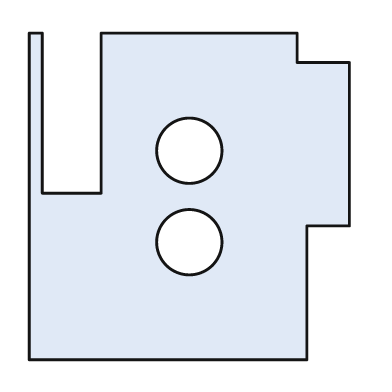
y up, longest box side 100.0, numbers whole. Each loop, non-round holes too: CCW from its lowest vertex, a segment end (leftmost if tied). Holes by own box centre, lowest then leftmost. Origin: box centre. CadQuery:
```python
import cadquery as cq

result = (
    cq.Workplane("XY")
    .moveTo(-49.0, -50.0)
    .lineTo(36.0, -50.0)
    .lineTo(36.0, -9.0)
    .lineTo(49.0, -9.0)
    .lineTo(49.0, 41.0)
    .lineTo(33.0, 41.0)
    .lineTo(33.0, 50.0)
    .lineTo(-27.0, 50.0)
    .lineTo(-27.0, 1.0)
    .lineTo(-45.0, 1.0)
    .lineTo(-45.0, 50.0)
    .lineTo(-49.0, 50.0)
    .close()
    .moveTo(0.0, -14.0)
    .circle(10.0)
    .moveTo(0.0, 14.0)
    .circle(10.0)
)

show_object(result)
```